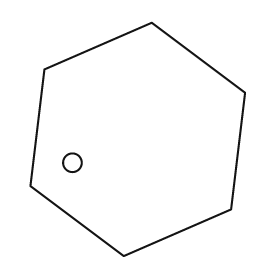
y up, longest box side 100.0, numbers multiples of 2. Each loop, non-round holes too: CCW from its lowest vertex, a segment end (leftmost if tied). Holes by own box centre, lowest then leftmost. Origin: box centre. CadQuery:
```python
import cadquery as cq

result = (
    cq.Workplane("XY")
    .moveTo(-6.0, -50.0)
    .lineTo(40.0, -30.0)
    .lineTo(46.0, 20.0)
    .lineTo(6.0, 50.0)
    .lineTo(-40.0, 30.0)
    .lineTo(-46.0, -20.0)
    .close()
    .moveTo(-28.0, -10.0)
    .circle(4.0)
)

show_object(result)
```